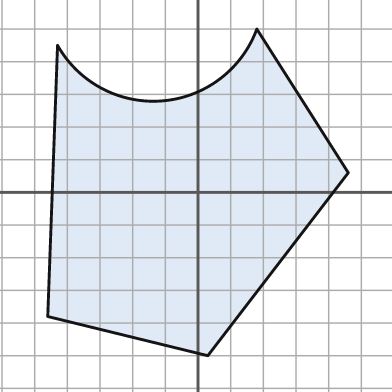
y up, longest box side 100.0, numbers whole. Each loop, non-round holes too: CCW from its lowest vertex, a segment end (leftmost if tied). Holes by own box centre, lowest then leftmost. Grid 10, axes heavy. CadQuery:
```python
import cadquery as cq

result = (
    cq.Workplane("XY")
    .moveTo(3.0, -50.0)
    .lineTo(46.0, 6.0)
    .lineTo(18.0, 50.0)
    .threePointArc((-11.0, 28.0), (-43.0, 45.0))
    .lineTo(-46.0, -38.0)
    .close()
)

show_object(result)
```